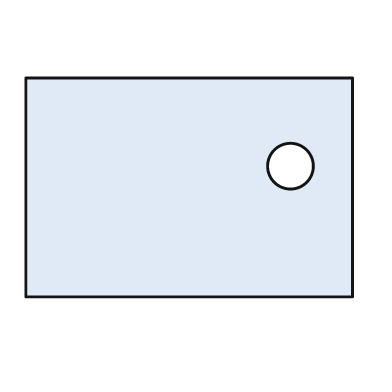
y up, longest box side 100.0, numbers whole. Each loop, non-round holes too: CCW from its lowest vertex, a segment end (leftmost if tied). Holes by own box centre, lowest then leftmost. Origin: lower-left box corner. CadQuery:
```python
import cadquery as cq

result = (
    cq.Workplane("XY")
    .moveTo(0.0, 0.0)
    .lineTo(100.0, 0.0)
    .lineTo(100.0, 67.0)
    .lineTo(0.0, 67.0)
    .close()
    .moveTo(81.0, 40.0)
    .circle(7.0)
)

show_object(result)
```